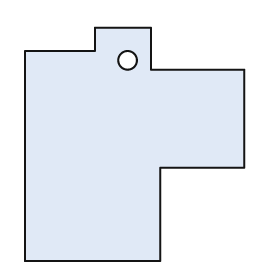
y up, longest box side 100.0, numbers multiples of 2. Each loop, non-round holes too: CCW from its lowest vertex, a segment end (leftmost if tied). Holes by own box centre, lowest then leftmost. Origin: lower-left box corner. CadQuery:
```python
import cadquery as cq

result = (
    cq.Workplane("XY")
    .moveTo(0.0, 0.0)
    .lineTo(58.0, 0.0)
    .lineTo(58.0, 40.0)
    .lineTo(94.0, 40.0)
    .lineTo(94.0, 82.0)
    .lineTo(54.0, 82.0)
    .lineTo(54.0, 100.0)
    .lineTo(30.0, 100.0)
    .lineTo(30.0, 90.0)
    .lineTo(0.0, 90.0)
    .close()
    .moveTo(44.0, 86.0)
    .circle(4.0)
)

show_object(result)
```